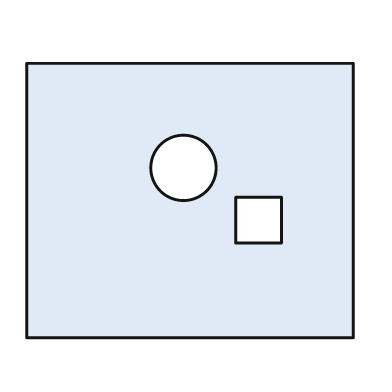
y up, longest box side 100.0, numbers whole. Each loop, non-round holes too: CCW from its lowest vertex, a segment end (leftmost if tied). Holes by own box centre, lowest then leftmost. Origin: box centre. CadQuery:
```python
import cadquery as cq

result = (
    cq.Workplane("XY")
    .moveTo(-50.0, -42.0)
    .lineTo(50.0, -42.0)
    .lineTo(50.0, 42.0)
    .lineTo(-50.0, 42.0)
    .close()
    .moveTo(14.0, -13.0)
    .lineTo(28.0, -13.0)
    .lineTo(28.0, 1.0)
    .lineTo(14.0, 1.0)
    .close()
    .moveTo(-2.0, 10.0)
    .circle(10.0)
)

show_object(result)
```